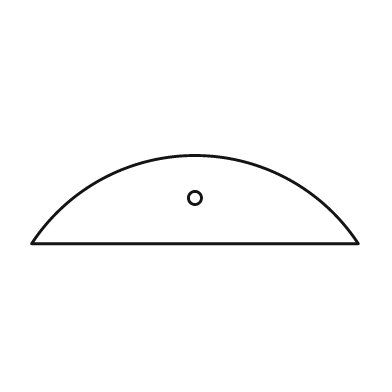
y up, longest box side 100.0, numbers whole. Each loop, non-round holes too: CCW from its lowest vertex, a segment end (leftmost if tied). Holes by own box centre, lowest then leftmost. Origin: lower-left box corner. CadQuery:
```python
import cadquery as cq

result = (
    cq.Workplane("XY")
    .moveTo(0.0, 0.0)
    .lineTo(100.0, 0.0)
    .threePointArc((50.0, 27.0), (0.0, 0.0))
    .close()
    .moveTo(50.0, 14.0)
    .circle(2.0)
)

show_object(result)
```